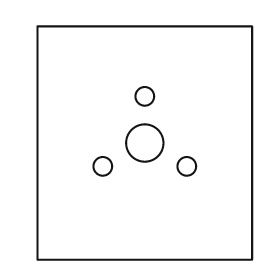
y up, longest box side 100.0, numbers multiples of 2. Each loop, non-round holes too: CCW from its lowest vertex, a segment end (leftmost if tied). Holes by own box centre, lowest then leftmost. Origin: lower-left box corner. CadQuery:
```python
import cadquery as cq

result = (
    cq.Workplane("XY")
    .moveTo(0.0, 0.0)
    .lineTo(92.0, 0.0)
    .lineTo(92.0, 100.0)
    .lineTo(0.0, 100.0)
    .close()
    .moveTo(28.0, 40.0)
    .circle(4.0)
    .moveTo(64.0, 40.0)
    .circle(4.0)
    .moveTo(46.0, 50.0)
    .circle(8.0)
    .moveTo(46.0, 70.0)
    .circle(4.0)
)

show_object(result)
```